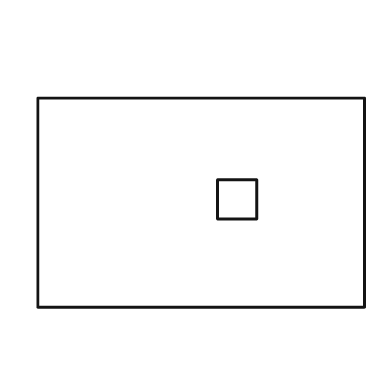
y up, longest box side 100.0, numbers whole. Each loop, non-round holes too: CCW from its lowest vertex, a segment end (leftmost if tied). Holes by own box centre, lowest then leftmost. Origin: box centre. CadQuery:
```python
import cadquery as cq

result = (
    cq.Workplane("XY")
    .moveTo(-50.0, -32.0)
    .lineTo(50.0, -32.0)
    .lineTo(50.0, 32.0)
    .lineTo(-50.0, 32.0)
    .close()
    .moveTo(5.0, -5.0)
    .lineTo(17.0, -5.0)
    .lineTo(17.0, 7.0)
    .lineTo(5.0, 7.0)
    .close()
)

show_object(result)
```